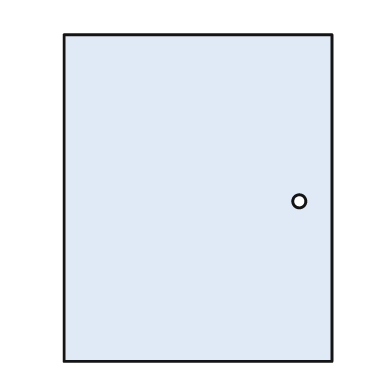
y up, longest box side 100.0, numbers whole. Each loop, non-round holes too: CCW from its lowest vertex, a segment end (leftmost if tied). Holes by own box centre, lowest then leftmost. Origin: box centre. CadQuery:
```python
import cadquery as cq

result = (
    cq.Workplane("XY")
    .moveTo(-41.0, -50.0)
    .lineTo(41.0, -50.0)
    .lineTo(41.0, 50.0)
    .lineTo(-41.0, 50.0)
    .close()
    .moveTo(31.0, -1.0)
    .circle(2.0)
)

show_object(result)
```